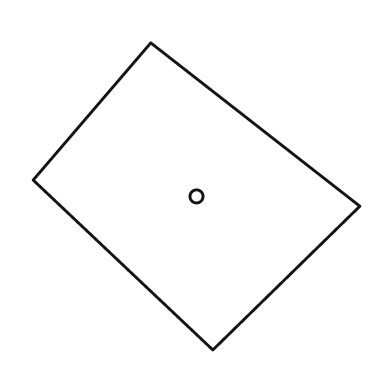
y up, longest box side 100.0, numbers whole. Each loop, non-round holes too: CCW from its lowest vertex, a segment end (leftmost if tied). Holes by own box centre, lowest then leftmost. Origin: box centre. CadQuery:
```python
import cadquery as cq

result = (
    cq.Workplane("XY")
    .moveTo(5.0, -47.0)
    .lineTo(50.0, -3.0)
    .lineTo(-14.0, 47.0)
    .lineTo(-50.0, 5.0)
    .close()
    .moveTo(0.0, 0.0)
    .circle(2.0)
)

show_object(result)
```